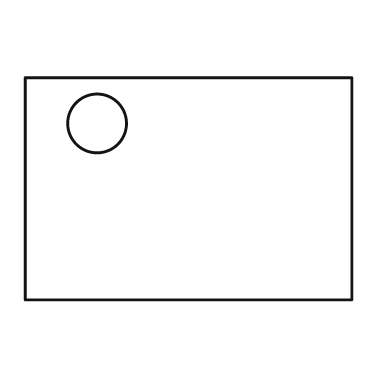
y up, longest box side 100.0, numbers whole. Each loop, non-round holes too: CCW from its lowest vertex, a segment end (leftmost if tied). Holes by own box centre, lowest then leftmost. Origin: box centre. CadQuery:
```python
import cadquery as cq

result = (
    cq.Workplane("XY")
    .moveTo(-50.0, -34.0)
    .lineTo(50.0, -34.0)
    .lineTo(50.0, 34.0)
    .lineTo(-50.0, 34.0)
    .close()
    .moveTo(-28.0, 20.0)
    .circle(9.0)
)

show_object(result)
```